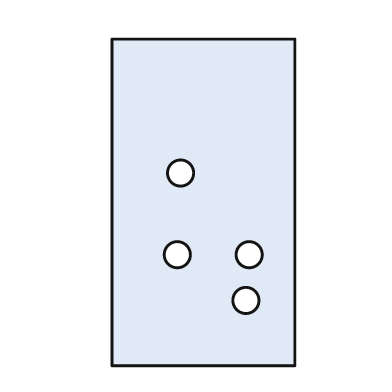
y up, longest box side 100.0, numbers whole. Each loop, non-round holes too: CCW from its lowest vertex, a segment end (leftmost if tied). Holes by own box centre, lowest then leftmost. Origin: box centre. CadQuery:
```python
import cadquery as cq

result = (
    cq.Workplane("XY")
    .moveTo(-28.0, -50.0)
    .lineTo(28.0, -50.0)
    .lineTo(28.0, 50.0)
    .lineTo(-28.0, 50.0)
    .close()
    .moveTo(13.0, -30.0)
    .circle(4.0)
    .moveTo(-8.0, -16.0)
    .circle(4.0)
    .moveTo(14.0, -16.0)
    .circle(4.0)
    .moveTo(-7.0, 9.0)
    .circle(4.0)
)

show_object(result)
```